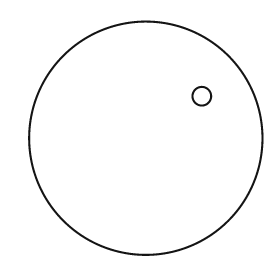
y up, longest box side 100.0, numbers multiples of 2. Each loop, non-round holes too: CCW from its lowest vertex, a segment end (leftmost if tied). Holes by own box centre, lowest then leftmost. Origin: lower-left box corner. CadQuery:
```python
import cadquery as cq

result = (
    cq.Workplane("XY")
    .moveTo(50.0, 50.0)
    .circle(50.0)
    .moveTo(74.0, 68.0)
    .circle(4.0)
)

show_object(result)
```